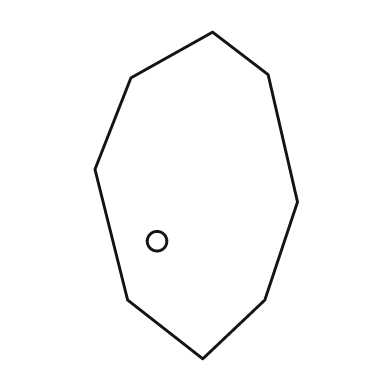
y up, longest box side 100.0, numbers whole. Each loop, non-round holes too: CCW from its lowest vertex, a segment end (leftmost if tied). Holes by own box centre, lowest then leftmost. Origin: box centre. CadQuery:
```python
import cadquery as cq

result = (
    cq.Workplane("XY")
    .moveTo(2.0, -50.0)
    .lineTo(21.0, -32.0)
    .lineTo(31.0, -2.0)
    .lineTo(22.0, 37.0)
    .lineTo(5.0, 50.0)
    .lineTo(-20.0, 36.0)
    .lineTo(-31.0, 8.0)
    .lineTo(-21.0, -32.0)
    .close()
    .moveTo(-12.0, -14.0)
    .circle(3.0)
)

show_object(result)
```